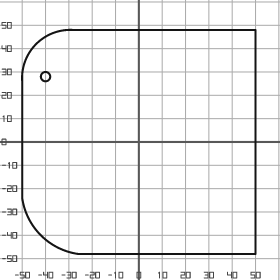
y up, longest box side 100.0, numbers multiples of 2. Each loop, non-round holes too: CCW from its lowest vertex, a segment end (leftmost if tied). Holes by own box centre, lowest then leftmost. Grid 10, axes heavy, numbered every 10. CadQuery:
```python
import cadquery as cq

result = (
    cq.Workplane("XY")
    .moveTo(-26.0, -48.0)
    .lineTo(50.0, -48.0)
    .lineTo(50.0, 48.0)
    .lineTo(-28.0, 48.0)
    .threePointArc((-44.0, 42.0), (-50.0, 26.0))
    .lineTo(-50.0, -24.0)
    .threePointArc((-42.0, -40.0), (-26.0, -48.0))
    .close()
    .moveTo(-40.0, 28.0)
    .circle(2.0)
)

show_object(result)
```